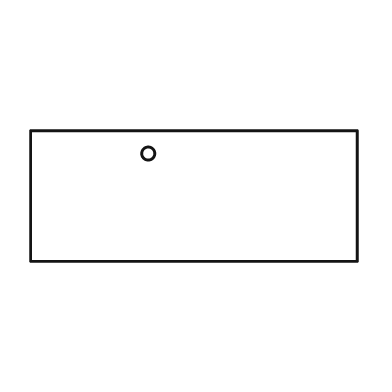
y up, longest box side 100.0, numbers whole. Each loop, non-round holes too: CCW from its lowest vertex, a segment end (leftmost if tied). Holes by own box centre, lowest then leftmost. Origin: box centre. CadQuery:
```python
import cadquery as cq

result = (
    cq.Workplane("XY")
    .moveTo(-50.0, -20.0)
    .lineTo(50.0, -20.0)
    .lineTo(50.0, 20.0)
    .lineTo(-50.0, 20.0)
    .close()
    .moveTo(-14.0, 13.0)
    .circle(2.0)
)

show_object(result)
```